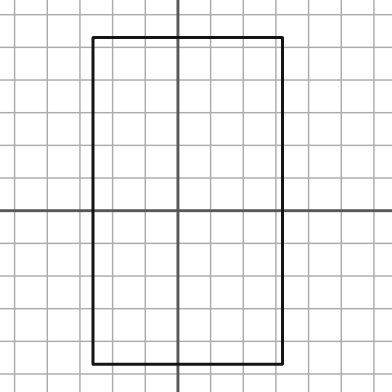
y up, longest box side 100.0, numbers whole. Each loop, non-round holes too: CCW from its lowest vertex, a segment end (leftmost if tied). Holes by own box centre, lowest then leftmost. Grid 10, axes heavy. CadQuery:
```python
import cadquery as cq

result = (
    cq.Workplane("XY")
    .moveTo(-26.0, -47.0)
    .lineTo(32.0, -47.0)
    .lineTo(32.0, 53.0)
    .lineTo(-26.0, 53.0)
    .close()
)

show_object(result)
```